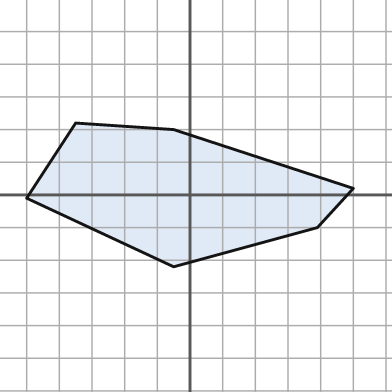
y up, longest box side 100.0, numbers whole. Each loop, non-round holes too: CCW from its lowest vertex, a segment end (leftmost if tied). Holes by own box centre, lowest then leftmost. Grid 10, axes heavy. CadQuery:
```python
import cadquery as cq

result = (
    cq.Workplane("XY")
    .moveTo(-5.0, -22.0)
    .lineTo(39.0, -10.0)
    .lineTo(50.0, 2.0)
    .lineTo(-5.0, 20.0)
    .lineTo(-35.0, 22.0)
    .lineTo(-50.0, -1.0)
    .close()
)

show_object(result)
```